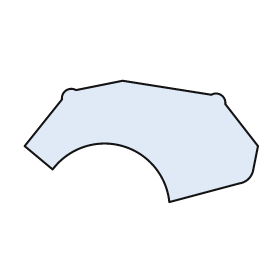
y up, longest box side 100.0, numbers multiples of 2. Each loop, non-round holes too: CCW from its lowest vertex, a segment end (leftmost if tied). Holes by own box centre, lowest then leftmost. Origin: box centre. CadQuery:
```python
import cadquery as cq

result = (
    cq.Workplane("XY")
    .moveTo(12.0, -26.0)
    .lineTo(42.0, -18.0)
    .threePointArc((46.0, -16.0), (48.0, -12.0))
    .lineTo(50.0, -2.0)
    .lineTo(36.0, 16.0)
    .threePointArc((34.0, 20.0), (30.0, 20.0))
    .lineTo(-8.0, 26.0)
    .lineTo(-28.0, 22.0)
    .threePointArc((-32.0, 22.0), (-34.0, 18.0))
    .lineTo(-50.0, -2.0)
    .lineTo(-38.0, -12.0)
    .threePointArc((-8.0, -2.0), (12.0, -26.0))
    .close()
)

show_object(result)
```